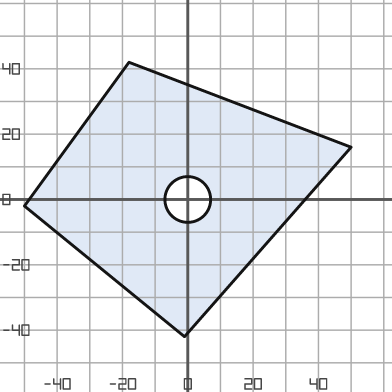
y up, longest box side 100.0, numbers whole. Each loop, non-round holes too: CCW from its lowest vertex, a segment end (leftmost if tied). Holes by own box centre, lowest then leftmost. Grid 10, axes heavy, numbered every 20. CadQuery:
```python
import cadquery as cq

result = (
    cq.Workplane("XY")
    .moveTo(-1.0, -42.0)
    .lineTo(50.0, 16.0)
    .lineTo(-18.0, 42.0)
    .lineTo(-50.0, -2.0)
    .close()
    .moveTo(0.0, 0.0)
    .circle(7.0)
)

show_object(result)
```